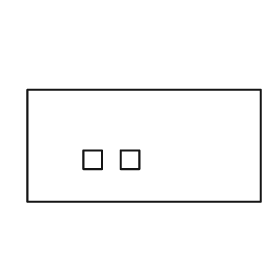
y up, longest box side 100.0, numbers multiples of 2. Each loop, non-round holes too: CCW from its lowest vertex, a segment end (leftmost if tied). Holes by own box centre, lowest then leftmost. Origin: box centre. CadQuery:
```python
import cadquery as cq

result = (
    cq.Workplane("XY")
    .moveTo(-50.0, -24.0)
    .lineTo(50.0, -24.0)
    .lineTo(50.0, 24.0)
    .lineTo(-50.0, 24.0)
    .close()
    .moveTo(-26.0, -10.0)
    .lineTo(-18.0, -10.0)
    .lineTo(-18.0, -2.0)
    .lineTo(-26.0, -2.0)
    .close()
    .moveTo(-10.0, -10.0)
    .lineTo(-2.0, -10.0)
    .lineTo(-2.0, -2.0)
    .lineTo(-10.0, -2.0)
    .close()
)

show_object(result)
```